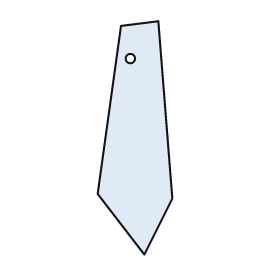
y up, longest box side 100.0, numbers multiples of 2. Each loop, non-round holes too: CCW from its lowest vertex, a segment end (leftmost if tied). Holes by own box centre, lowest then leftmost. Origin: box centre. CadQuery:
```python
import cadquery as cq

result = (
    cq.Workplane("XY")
    .moveTo(4.0, -50.0)
    .lineTo(16.0, -26.0)
    .lineTo(10.0, 50.0)
    .lineTo(-6.0, 48.0)
    .lineTo(-16.0, -24.0)
    .close()
    .moveTo(-2.0, 34.0)
    .circle(2.0)
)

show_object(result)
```